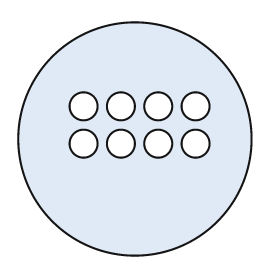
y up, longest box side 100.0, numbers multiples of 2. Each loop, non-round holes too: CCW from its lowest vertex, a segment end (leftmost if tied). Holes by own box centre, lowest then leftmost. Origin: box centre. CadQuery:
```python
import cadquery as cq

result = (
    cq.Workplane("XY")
    .moveTo(0.0, 0.0)
    .circle(50.0)
    .moveTo(-22.0, -2.0)
    .circle(6.0)
    .moveTo(-6.0, -2.0)
    .circle(6.0)
    .moveTo(10.0, -2.0)
    .circle(6.0)
    .moveTo(26.0, -2.0)
    .circle(6.0)
    .moveTo(-22.0, 14.0)
    .circle(6.0)
    .moveTo(-6.0, 14.0)
    .circle(6.0)
    .moveTo(10.0, 14.0)
    .circle(6.0)
    .moveTo(26.0, 14.0)
    .circle(6.0)
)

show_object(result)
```